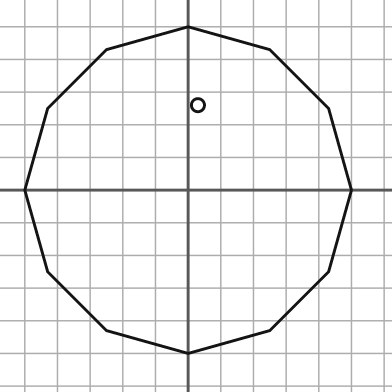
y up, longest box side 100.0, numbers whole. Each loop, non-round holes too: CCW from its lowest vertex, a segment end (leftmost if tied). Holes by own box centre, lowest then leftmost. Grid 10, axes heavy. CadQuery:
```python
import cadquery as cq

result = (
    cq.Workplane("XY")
    .moveTo(0.0, -50.0)
    .lineTo(25.0, -43.0)
    .lineTo(43.0, -25.0)
    .lineTo(50.0, 0.0)
    .lineTo(43.0, 25.0)
    .lineTo(25.0, 43.0)
    .lineTo(0.0, 50.0)
    .lineTo(-25.0, 43.0)
    .lineTo(-43.0, 25.0)
    .lineTo(-50.0, 0.0)
    .lineTo(-43.0, -25.0)
    .lineTo(-25.0, -43.0)
    .close()
    .moveTo(3.0, 26.0)
    .circle(2.0)
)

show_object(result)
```